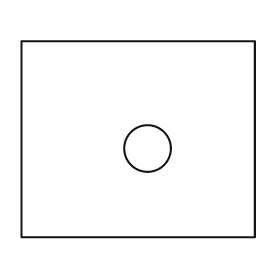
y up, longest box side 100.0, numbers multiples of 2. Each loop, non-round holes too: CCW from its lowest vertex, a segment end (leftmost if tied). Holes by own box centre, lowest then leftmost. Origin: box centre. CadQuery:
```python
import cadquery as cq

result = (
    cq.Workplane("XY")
    .moveTo(-50.0, -42.0)
    .lineTo(50.0, -42.0)
    .lineTo(50.0, 42.0)
    .lineTo(-50.0, 42.0)
    .close()
    .moveTo(4.0, -4.0)
    .circle(10.0)
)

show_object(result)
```